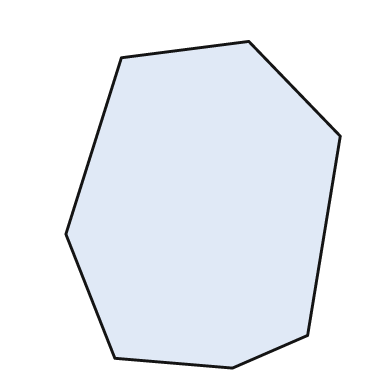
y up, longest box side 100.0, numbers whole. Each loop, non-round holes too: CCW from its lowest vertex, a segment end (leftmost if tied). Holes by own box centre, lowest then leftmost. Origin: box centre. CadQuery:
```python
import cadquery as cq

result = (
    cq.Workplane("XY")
    .moveTo(9.0, -50.0)
    .lineTo(32.0, -40.0)
    .lineTo(42.0, 21.0)
    .lineTo(14.0, 50.0)
    .lineTo(-25.0, 45.0)
    .lineTo(-42.0, -9.0)
    .lineTo(-27.0, -47.0)
    .close()
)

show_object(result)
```